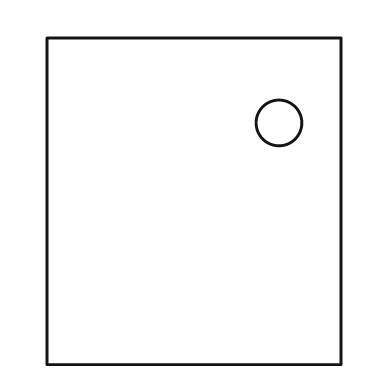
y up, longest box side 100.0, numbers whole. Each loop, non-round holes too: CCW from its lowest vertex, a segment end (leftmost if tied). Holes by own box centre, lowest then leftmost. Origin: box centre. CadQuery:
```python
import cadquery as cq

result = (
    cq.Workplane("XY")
    .moveTo(-45.0, -50.0)
    .lineTo(45.0, -50.0)
    .lineTo(45.0, 50.0)
    .lineTo(-45.0, 50.0)
    .close()
    .moveTo(26.0, 24.0)
    .circle(7.0)
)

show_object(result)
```